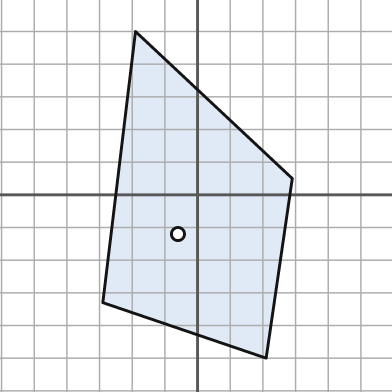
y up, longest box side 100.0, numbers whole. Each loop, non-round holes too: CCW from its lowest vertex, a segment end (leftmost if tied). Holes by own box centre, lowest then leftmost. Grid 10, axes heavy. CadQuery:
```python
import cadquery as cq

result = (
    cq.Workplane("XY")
    .moveTo(21.0, -50.0)
    .lineTo(29.0, 5.0)
    .lineTo(-19.0, 50.0)
    .lineTo(-29.0, -33.0)
    .close()
    .moveTo(-6.0, -12.0)
    .circle(2.0)
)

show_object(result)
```